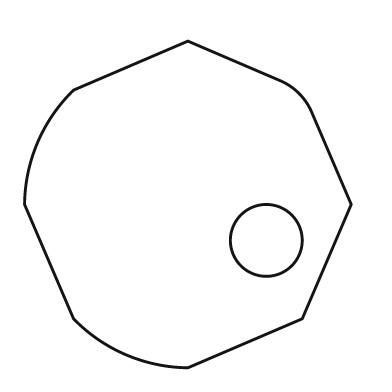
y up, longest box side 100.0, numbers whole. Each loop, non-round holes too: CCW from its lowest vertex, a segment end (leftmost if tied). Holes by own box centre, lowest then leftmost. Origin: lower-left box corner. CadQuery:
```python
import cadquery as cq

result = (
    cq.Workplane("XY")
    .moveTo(50.0, 0.0)
    .lineTo(85.0, 15.0)
    .lineTo(100.0, 50.0)
    .lineTo(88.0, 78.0)
    .threePointArc((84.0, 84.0), (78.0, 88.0))
    .lineTo(50.0, 100.0)
    .lineTo(15.0, 85.0)
    .threePointArc((4.0, 69.0), (0.0, 50.0))
    .lineTo(15.0, 15.0)
    .threePointArc((31.0, 4.0), (50.0, 0.0))
    .close()
    .moveTo(74.0, 39.0)
    .circle(11.0)
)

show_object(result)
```